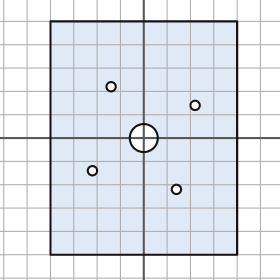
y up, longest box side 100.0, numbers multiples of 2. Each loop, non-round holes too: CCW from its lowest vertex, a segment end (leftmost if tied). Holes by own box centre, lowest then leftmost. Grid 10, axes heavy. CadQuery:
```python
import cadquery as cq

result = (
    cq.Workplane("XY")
    .moveTo(-40.0, -50.0)
    .lineTo(40.0, -50.0)
    .lineTo(40.0, 50.0)
    .lineTo(-40.0, 50.0)
    .close()
    .moveTo(14.0, -22.0)
    .circle(2.0)
    .moveTo(-22.0, -14.0)
    .circle(2.0)
    .moveTo(0.0, 0.0)
    .circle(6.0)
    .moveTo(22.0, 14.0)
    .circle(2.0)
    .moveTo(-14.0, 22.0)
    .circle(2.0)
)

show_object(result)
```